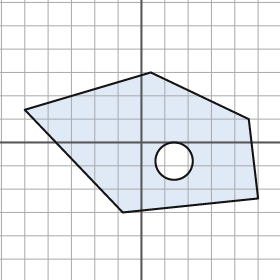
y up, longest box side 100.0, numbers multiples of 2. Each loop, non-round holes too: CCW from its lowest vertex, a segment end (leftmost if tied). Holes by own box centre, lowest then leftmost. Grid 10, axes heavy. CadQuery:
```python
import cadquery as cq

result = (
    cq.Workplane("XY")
    .moveTo(-8.0, -30.0)
    .lineTo(50.0, -24.0)
    .lineTo(46.0, 10.0)
    .lineTo(4.0, 30.0)
    .lineTo(-50.0, 14.0)
    .close()
    .moveTo(14.0, -8.0)
    .circle(8.0)
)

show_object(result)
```